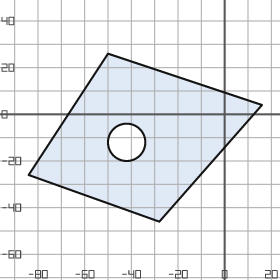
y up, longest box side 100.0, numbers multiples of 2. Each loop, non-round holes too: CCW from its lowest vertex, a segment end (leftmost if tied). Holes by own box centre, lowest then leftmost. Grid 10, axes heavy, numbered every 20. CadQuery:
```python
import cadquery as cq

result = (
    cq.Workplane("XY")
    .moveTo(-28.0, -46.0)
    .lineTo(16.0, 4.0)
    .lineTo(-50.0, 26.0)
    .lineTo(-84.0, -26.0)
    .close()
    .moveTo(-42.0, -12.0)
    .circle(8.0)
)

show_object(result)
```